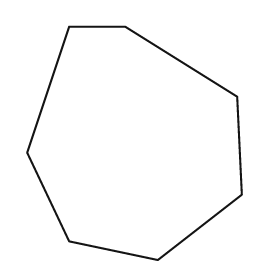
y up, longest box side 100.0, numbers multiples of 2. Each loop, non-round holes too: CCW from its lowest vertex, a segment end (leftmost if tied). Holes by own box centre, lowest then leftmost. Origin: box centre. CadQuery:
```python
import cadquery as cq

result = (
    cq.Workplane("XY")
    .moveTo(10.0, -50.0)
    .lineTo(46.0, -22.0)
    .lineTo(44.0, 20.0)
    .lineTo(-4.0, 50.0)
    .lineTo(-28.0, 50.0)
    .lineTo(-46.0, -4.0)
    .lineTo(-28.0, -42.0)
    .close()
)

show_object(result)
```